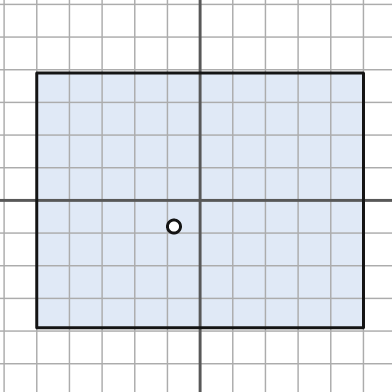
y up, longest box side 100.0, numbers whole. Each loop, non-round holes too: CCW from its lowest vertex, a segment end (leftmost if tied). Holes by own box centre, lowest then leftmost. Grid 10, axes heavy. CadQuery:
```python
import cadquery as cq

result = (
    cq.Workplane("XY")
    .moveTo(-50.0, -39.0)
    .lineTo(50.0, -39.0)
    .lineTo(50.0, 39.0)
    .lineTo(-50.0, 39.0)
    .close()
    .moveTo(-8.0, -8.0)
    .circle(2.0)
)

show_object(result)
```